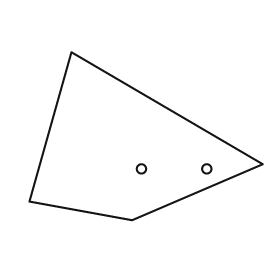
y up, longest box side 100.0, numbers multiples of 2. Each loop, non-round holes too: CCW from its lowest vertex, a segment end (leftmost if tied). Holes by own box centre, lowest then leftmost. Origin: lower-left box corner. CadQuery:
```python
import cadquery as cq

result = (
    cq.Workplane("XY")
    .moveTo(44.0, 0.0)
    .lineTo(100.0, 24.0)
    .lineTo(18.0, 72.0)
    .lineTo(0.0, 8.0)
    .close()
    .moveTo(48.0, 22.0)
    .circle(2.0)
    .moveTo(76.0, 22.0)
    .circle(2.0)
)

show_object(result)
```